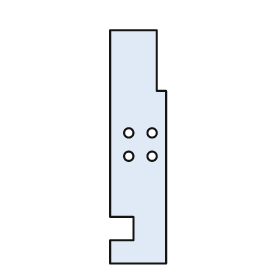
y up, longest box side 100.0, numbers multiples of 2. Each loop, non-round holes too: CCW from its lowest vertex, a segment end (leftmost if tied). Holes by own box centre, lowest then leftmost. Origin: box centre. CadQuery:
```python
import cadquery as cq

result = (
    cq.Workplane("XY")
    .moveTo(-12.0, -50.0)
    .lineTo(12.0, -50.0)
    .lineTo(12.0, 24.0)
    .lineTo(8.0, 24.0)
    .lineTo(8.0, 50.0)
    .lineTo(-12.0, 50.0)
    .lineTo(-12.0, -30.0)
    .lineTo(-2.0, -30.0)
    .lineTo(-2.0, -40.0)
    .lineTo(-12.0, -40.0)
    .close()
    .moveTo(-4.0, -4.0)
    .circle(2.0)
    .moveTo(6.0, -4.0)
    .circle(2.0)
    .moveTo(-4.0, 6.0)
    .circle(2.0)
    .moveTo(6.0, 6.0)
    .circle(2.0)
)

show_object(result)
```